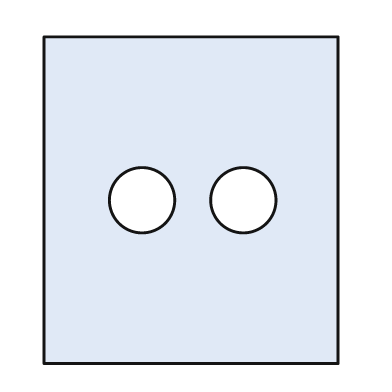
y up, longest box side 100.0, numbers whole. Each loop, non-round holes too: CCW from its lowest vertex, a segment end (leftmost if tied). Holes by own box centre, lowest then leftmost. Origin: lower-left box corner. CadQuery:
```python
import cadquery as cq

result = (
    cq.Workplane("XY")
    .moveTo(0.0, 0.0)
    .lineTo(90.0, 0.0)
    .lineTo(90.0, 100.0)
    .lineTo(0.0, 100.0)
    .close()
    .moveTo(30.0, 50.0)
    .circle(10.0)
    .moveTo(61.0, 50.0)
    .circle(10.0)
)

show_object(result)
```